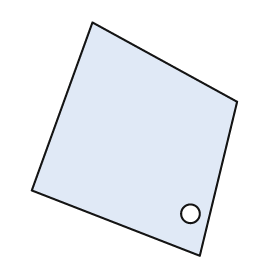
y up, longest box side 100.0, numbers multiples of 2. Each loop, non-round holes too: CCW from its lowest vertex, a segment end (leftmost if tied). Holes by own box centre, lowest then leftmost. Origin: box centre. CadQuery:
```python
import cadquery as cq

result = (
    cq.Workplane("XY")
    .moveTo(28.0, -50.0)
    .lineTo(44.0, 16.0)
    .lineTo(-18.0, 50.0)
    .lineTo(-44.0, -22.0)
    .close()
    .moveTo(24.0, -32.0)
    .circle(4.0)
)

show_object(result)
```